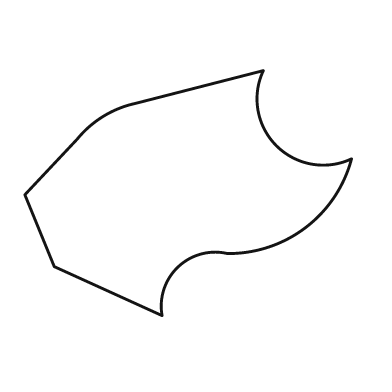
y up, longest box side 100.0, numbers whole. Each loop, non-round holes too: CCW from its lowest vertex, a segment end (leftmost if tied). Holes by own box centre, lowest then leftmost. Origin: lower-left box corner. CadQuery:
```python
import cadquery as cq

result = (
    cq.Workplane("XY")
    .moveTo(42.0, 0.0)
    .threePointArc((47.0, 15.0), (62.0, 19.0))
    .threePointArc((86.0, 27.0), (100.0, 48.0))
    .threePointArc((77.0, 52.0), (73.0, 75.0))
    .lineTo(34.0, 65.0)
    .threePointArc((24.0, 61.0), (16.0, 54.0))
    .lineTo(0.0, 37.0)
    .lineTo(9.0, 15.0)
    .close()
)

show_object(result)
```